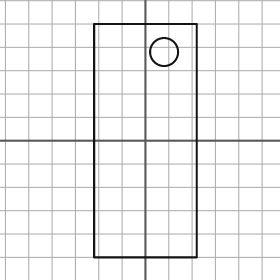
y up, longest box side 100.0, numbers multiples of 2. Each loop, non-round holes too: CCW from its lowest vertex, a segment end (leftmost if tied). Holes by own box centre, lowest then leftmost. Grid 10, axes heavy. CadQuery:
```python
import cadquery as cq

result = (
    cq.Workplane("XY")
    .moveTo(-22.0, -50.0)
    .lineTo(22.0, -50.0)
    .lineTo(22.0, 50.0)
    .lineTo(-22.0, 50.0)
    .close()
    .moveTo(8.0, 38.0)
    .circle(6.0)
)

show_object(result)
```